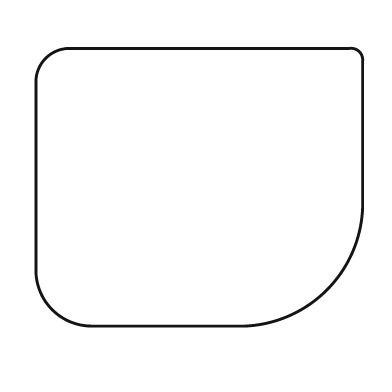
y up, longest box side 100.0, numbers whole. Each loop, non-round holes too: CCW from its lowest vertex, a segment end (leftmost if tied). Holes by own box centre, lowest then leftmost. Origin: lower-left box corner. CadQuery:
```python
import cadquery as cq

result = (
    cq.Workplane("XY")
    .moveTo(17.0, 0.0)
    .lineTo(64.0, 0.0)
    .threePointArc((89.0, 11.0), (100.0, 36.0))
    .lineTo(100.0, 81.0)
    .threePointArc((99.0, 84.0), (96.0, 85.0))
    .lineTo(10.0, 85.0)
    .threePointArc((3.0, 82.0), (0.0, 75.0))
    .lineTo(0.0, 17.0)
    .threePointArc((5.0, 5.0), (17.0, 0.0))
    .close()
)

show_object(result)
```